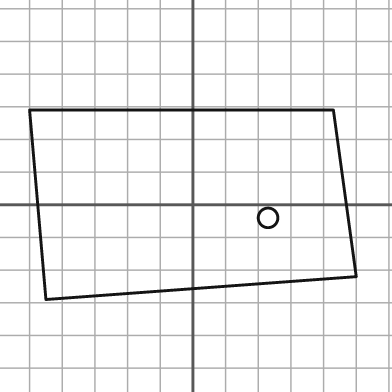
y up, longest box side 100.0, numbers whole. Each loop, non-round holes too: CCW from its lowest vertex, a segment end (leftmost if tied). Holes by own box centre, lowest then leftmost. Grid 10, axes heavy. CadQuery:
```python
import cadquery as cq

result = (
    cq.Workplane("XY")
    .moveTo(-45.0, -29.0)
    .lineTo(50.0, -22.0)
    .lineTo(43.0, 29.0)
    .lineTo(-50.0, 29.0)
    .close()
    .moveTo(23.0, -4.0)
    .circle(3.0)
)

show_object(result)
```